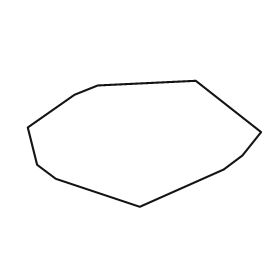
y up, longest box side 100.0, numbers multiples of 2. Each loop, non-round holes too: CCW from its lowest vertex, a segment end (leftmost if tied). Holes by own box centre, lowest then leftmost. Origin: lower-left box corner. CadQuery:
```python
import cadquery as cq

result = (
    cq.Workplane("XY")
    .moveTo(48.0, 0.0)
    .lineTo(84.0, 16.0)
    .lineTo(92.0, 22.0)
    .lineTo(100.0, 32.0)
    .lineTo(72.0, 54.0)
    .lineTo(30.0, 52.0)
    .lineTo(20.0, 48.0)
    .lineTo(0.0, 34.0)
    .lineTo(4.0, 18.0)
    .lineTo(12.0, 12.0)
    .close()
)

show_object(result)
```